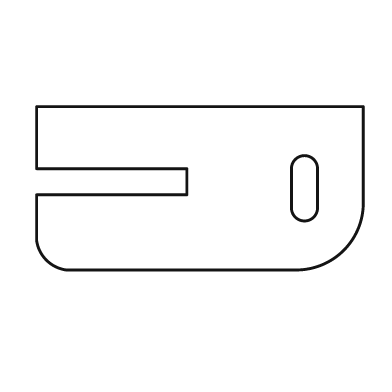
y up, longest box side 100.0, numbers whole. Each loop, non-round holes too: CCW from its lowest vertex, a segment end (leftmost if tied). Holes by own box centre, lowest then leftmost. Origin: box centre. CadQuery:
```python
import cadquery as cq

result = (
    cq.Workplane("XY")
    .moveTo(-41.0, -25.0)
    .lineTo(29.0, -25.0)
    .threePointArc((44.0, -19.0), (50.0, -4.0))
    .lineTo(50.0, 25.0)
    .lineTo(-50.0, 25.0)
    .lineTo(-50.0, 6.0)
    .lineTo(-4.0, 6.0)
    .lineTo(-4.0, -2.0)
    .lineTo(-50.0, -2.0)
    .lineTo(-50.0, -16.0)
    .threePointArc((-47.0, -22.0), (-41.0, -25.0))
    .close()
    .moveTo(28.0, -6.0)
    .threePointArc((32.0, -10.0), (36.0, -6.0))
    .lineTo(36.0, 6.0)
    .threePointArc((32.0, 10.0), (28.0, 6.0))
    .close()
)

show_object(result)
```